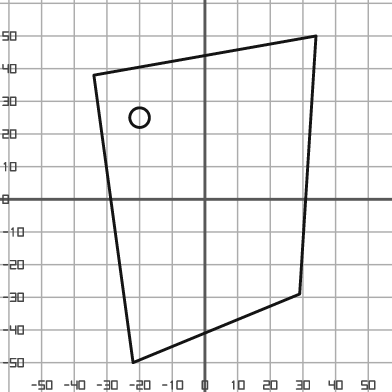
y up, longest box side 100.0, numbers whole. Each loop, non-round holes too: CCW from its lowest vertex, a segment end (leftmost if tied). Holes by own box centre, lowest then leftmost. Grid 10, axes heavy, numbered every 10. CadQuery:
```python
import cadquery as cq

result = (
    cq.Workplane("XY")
    .moveTo(-22.0, -50.0)
    .lineTo(29.0, -29.0)
    .lineTo(34.0, 50.0)
    .lineTo(-34.0, 38.0)
    .close()
    .moveTo(-20.0, 25.0)
    .circle(3.0)
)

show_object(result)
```